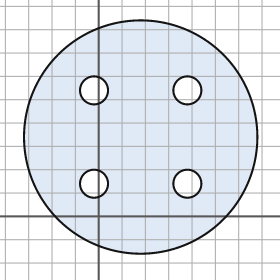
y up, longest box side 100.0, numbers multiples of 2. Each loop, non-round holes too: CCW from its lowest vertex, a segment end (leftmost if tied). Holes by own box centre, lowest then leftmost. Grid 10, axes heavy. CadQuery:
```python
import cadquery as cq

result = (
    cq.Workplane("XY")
    .moveTo(18.0, 34.0)
    .circle(50.0)
    .moveTo(-2.0, 14.0)
    .circle(6.0)
    .moveTo(38.0, 14.0)
    .circle(6.0)
    .moveTo(-2.0, 54.0)
    .circle(6.0)
    .moveTo(38.0, 54.0)
    .circle(6.0)
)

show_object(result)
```